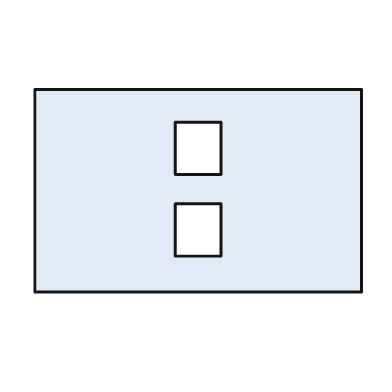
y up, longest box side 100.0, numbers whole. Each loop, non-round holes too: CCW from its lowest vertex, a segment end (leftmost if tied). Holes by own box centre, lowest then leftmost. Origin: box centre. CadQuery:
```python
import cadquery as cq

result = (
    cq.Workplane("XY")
    .moveTo(-50.0, -31.0)
    .lineTo(50.0, -31.0)
    .lineTo(50.0, 31.0)
    .lineTo(-50.0, 31.0)
    .close()
    .moveTo(-7.0, -20.0)
    .lineTo(7.0, -20.0)
    .lineTo(7.0, -4.0)
    .lineTo(-7.0, -4.0)
    .close()
    .moveTo(-7.0, 5.0)
    .lineTo(7.0, 5.0)
    .lineTo(7.0, 21.0)
    .lineTo(-7.0, 21.0)
    .close()
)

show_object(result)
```